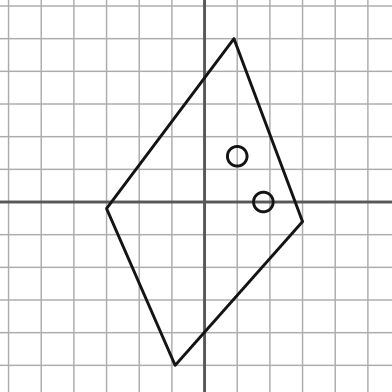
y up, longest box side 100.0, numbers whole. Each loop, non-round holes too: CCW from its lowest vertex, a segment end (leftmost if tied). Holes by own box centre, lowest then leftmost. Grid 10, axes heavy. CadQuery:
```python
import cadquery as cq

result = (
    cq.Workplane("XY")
    .moveTo(-9.0, -50.0)
    .lineTo(30.0, -6.0)
    .lineTo(9.0, 50.0)
    .lineTo(-30.0, -2.0)
    .close()
    .moveTo(18.0, 0.0)
    .circle(3.0)
    .moveTo(10.0, 14.0)
    .circle(3.0)
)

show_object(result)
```